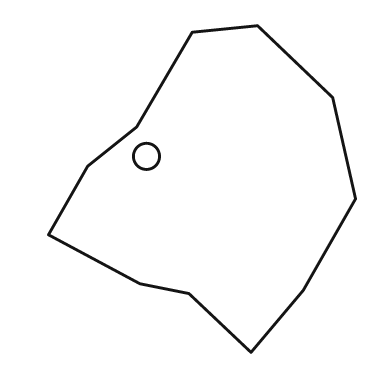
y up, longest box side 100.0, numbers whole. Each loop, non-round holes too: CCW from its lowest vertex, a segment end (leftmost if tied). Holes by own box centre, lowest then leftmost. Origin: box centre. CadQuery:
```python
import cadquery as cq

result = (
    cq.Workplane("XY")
    .moveTo(15.0, -50.0)
    .lineTo(31.0, -31.0)
    .lineTo(47.0, -3.0)
    .lineTo(40.0, 28.0)
    .lineTo(17.0, 50.0)
    .lineTo(-3.0, 48.0)
    .lineTo(-20.0, 19.0)
    .lineTo(-35.0, 7.0)
    .lineTo(-47.0, -14.0)
    .lineTo(-19.0, -29.0)
    .lineTo(-4.0, -32.0)
    .close()
    .moveTo(-17.0, 10.0)
    .circle(4.0)
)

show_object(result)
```